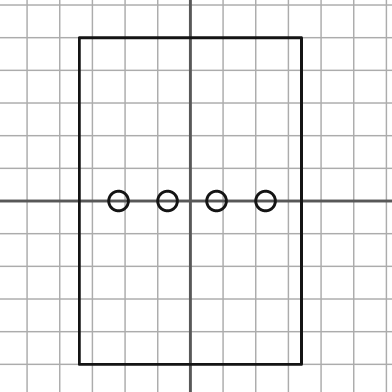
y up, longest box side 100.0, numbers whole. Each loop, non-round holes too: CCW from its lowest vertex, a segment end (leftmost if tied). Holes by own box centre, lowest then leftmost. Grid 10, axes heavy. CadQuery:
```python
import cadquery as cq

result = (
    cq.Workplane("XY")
    .moveTo(-34.0, -50.0)
    .lineTo(34.0, -50.0)
    .lineTo(34.0, 50.0)
    .lineTo(-34.0, 50.0)
    .close()
    .moveTo(-22.0, 0.0)
    .circle(3.0)
    .moveTo(-7.0, 0.0)
    .circle(3.0)
    .moveTo(8.0, 0.0)
    .circle(3.0)
    .moveTo(23.0, 0.0)
    .circle(3.0)
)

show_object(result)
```